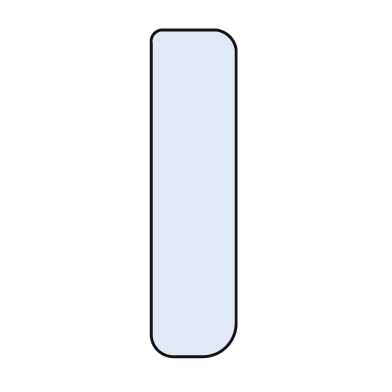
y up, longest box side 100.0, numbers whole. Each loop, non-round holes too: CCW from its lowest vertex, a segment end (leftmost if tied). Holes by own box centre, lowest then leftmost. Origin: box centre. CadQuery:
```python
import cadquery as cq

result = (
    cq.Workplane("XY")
    .moveTo(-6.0, -50.0)
    .lineTo(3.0, -50.0)
    .threePointArc((10.0, -47.0), (13.0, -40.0))
    .lineTo(13.0, 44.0)
    .threePointArc((11.0, 48.0), (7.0, 50.0))
    .lineTo(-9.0, 50.0)
    .threePointArc((-12.0, 49.0), (-13.0, 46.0))
    .lineTo(-13.0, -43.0)
    .threePointArc((-11.0, -48.0), (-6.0, -50.0))
    .close()
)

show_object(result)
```